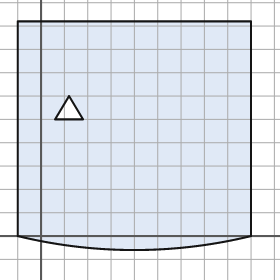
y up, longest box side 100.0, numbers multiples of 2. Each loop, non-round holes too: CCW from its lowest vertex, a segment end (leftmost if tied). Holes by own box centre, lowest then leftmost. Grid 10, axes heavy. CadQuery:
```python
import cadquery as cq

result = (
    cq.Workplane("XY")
    .moveTo(-10.0, 0.0)
    .threePointArc((40.0, -6.0), (90.0, 0.0))
    .lineTo(90.0, 92.0)
    .lineTo(-10.0, 92.0)
    .close()
    .moveTo(6.0, 50.0)
    .lineTo(18.0, 50.0)
    .lineTo(12.0, 60.0)
    .close()
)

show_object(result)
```